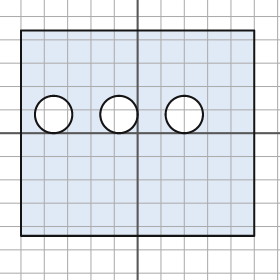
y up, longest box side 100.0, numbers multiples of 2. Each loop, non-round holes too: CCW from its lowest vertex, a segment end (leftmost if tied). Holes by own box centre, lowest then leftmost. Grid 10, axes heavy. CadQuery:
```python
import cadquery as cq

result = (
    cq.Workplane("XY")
    .moveTo(-50.0, -44.0)
    .lineTo(50.0, -44.0)
    .lineTo(50.0, 44.0)
    .lineTo(-50.0, 44.0)
    .close()
    .moveTo(-36.0, 8.0)
    .circle(8.0)
    .moveTo(-8.0, 8.0)
    .circle(8.0)
    .moveTo(20.0, 8.0)
    .circle(8.0)
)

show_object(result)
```